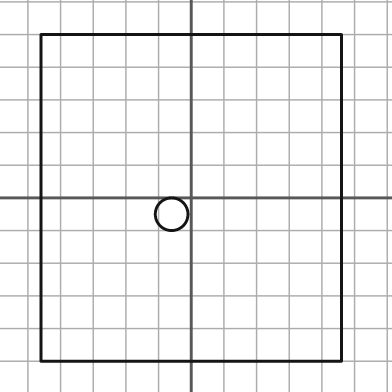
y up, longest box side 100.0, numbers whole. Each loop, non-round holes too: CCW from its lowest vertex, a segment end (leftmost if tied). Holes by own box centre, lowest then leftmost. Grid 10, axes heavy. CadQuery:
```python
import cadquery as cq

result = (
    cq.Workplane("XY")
    .moveTo(-46.0, -50.0)
    .lineTo(46.0, -50.0)
    .lineTo(46.0, 50.0)
    .lineTo(-46.0, 50.0)
    .close()
    .moveTo(-6.0, -5.0)
    .circle(5.0)
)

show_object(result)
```